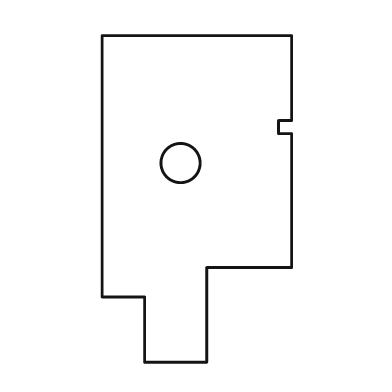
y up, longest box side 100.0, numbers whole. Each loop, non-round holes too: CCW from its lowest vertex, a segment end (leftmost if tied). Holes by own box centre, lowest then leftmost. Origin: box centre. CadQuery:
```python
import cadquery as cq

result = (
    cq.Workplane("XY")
    .moveTo(-16.0, -50.0)
    .lineTo(3.0, -50.0)
    .lineTo(3.0, -21.0)
    .lineTo(29.0, -21.0)
    .lineTo(29.0, 20.0)
    .lineTo(25.0, 20.0)
    .lineTo(25.0, 24.0)
    .lineTo(29.0, 24.0)
    .lineTo(29.0, 50.0)
    .lineTo(-29.0, 50.0)
    .lineTo(-29.0, -30.0)
    .lineTo(-16.0, -30.0)
    .close()
    .moveTo(-5.0, 11.0)
    .circle(6.0)
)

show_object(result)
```